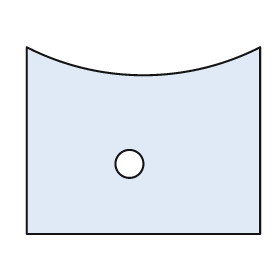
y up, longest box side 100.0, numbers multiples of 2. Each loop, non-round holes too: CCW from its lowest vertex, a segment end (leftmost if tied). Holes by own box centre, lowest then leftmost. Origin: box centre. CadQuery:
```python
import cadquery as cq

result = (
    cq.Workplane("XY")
    .moveTo(-50.0, -40.0)
    .lineTo(50.0, -40.0)
    .lineTo(50.0, 40.0)
    .threePointArc((0.0, 28.0), (-50.0, 40.0))
    .close()
    .moveTo(-6.0, -10.0)
    .circle(6.0)
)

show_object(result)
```